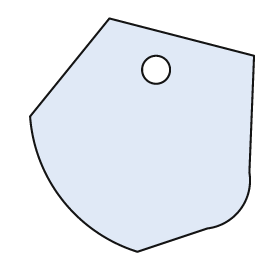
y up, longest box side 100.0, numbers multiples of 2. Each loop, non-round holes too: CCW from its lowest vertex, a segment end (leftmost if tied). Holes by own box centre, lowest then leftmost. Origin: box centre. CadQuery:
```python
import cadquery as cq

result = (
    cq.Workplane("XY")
    .moveTo(-2.0, -50.0)
    .lineTo(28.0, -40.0)
    .threePointArc((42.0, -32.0), (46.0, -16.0))
    .lineTo(48.0, 34.0)
    .lineTo(-14.0, 50.0)
    .lineTo(-48.0, 8.0)
    .threePointArc((-34.0, -28.0), (-2.0, -50.0))
    .close()
    .moveTo(6.0, 28.0)
    .circle(6.0)
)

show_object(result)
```